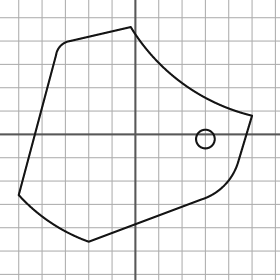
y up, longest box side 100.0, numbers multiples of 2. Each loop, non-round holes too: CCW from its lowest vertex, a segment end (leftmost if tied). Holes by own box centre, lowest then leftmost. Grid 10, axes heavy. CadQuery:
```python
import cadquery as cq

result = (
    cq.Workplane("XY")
    .moveTo(-20.0, -46.0)
    .lineTo(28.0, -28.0)
    .threePointArc((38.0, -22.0), (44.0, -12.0))
    .lineTo(50.0, 8.0)
    .threePointArc((20.0, 22.0), (-2.0, 46.0))
    .lineTo(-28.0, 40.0)
    .threePointArc((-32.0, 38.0), (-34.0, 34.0))
    .lineTo(-50.0, -26.0)
    .threePointArc((-36.0, -38.0), (-20.0, -46.0))
    .close()
    .moveTo(30.0, -2.0)
    .circle(4.0)
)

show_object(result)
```